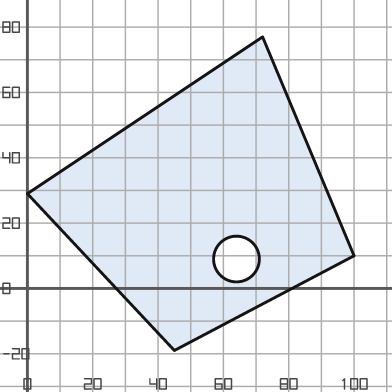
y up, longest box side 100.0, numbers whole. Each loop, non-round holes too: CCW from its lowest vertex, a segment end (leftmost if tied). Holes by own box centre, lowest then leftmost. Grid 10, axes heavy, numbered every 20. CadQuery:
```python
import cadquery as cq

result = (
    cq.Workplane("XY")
    .moveTo(45.0, -19.0)
    .lineTo(100.0, 10.0)
    .lineTo(72.0, 77.0)
    .lineTo(0.0, 29.0)
    .close()
    .moveTo(64.0, 9.0)
    .circle(7.0)
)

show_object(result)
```